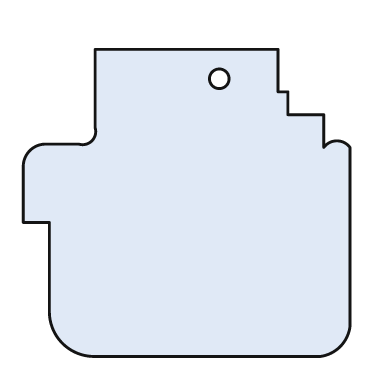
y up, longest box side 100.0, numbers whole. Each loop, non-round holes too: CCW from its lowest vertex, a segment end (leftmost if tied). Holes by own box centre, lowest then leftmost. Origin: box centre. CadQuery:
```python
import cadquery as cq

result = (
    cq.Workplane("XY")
    .moveTo(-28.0, -47.0)
    .lineTo(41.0, -47.0)
    .threePointArc((47.0, -44.0), (50.0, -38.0))
    .lineTo(50.0, 17.0)
    .threePointArc((46.0, 19.0), (42.0, 17.0))
    .lineTo(42.0, 27.0)
    .lineTo(31.0, 27.0)
    .lineTo(31.0, 34.0)
    .lineTo(28.0, 34.0)
    .lineTo(28.0, 47.0)
    .lineTo(-28.0, 47.0)
    .lineTo(-28.0, 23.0)
    .threePointArc((-29.0, 19.0), (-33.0, 18.0))
    .lineTo(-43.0, 18.0)
    .threePointArc((-48.0, 16.0), (-50.0, 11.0))
    .lineTo(-50.0, -6.0)
    .lineTo(-42.0, -6.0)
    .lineTo(-42.0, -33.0)
    .threePointArc((-38.0, -43.0), (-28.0, -47.0))
    .close()
    .moveTo(10.0, 38.0)
    .circle(3.0)
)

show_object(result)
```